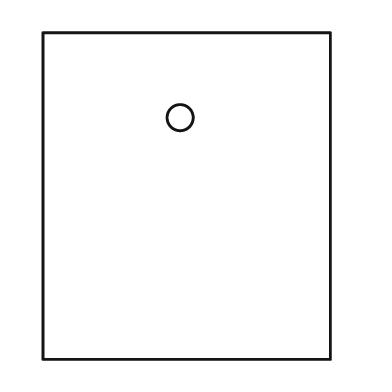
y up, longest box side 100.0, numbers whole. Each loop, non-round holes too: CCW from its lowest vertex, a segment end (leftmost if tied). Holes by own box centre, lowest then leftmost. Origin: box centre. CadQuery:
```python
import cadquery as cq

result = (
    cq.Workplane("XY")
    .moveTo(-44.0, -50.0)
    .lineTo(44.0, -50.0)
    .lineTo(44.0, 50.0)
    .lineTo(-44.0, 50.0)
    .close()
    .moveTo(-2.0, 24.0)
    .circle(4.0)
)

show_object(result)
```